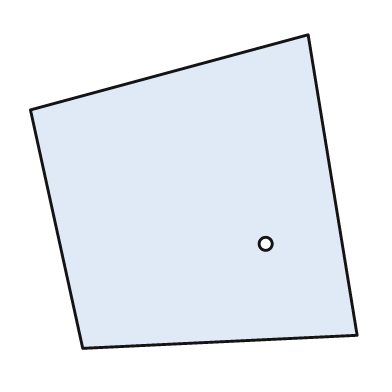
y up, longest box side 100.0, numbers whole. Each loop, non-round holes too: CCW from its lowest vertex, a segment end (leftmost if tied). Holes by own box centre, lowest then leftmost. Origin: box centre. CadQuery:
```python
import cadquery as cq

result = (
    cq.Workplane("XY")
    .moveTo(-34.0, -48.0)
    .lineTo(50.0, -44.0)
    .lineTo(35.0, 48.0)
    .lineTo(-50.0, 25.0)
    .close()
    .moveTo(22.0, -16.0)
    .circle(2.0)
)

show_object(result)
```